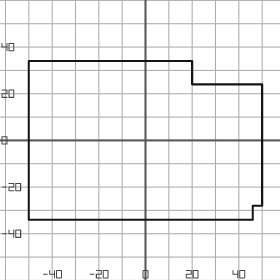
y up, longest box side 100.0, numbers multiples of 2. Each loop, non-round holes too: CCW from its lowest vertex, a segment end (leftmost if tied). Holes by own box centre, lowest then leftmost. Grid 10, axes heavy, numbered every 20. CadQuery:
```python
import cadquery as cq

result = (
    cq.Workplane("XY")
    .moveTo(-50.0, -34.0)
    .lineTo(46.0, -34.0)
    .lineTo(46.0, -28.0)
    .lineTo(50.0, -28.0)
    .lineTo(50.0, 24.0)
    .lineTo(20.0, 24.0)
    .lineTo(20.0, 34.0)
    .lineTo(-50.0, 34.0)
    .close()
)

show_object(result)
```